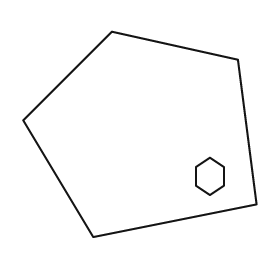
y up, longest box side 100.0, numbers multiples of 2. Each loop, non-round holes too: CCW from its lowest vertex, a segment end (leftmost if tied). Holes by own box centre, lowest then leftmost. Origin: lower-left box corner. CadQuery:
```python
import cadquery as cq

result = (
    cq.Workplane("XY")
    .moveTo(30.0, 0.0)
    .lineTo(100.0, 14.0)
    .lineTo(92.0, 76.0)
    .lineTo(38.0, 88.0)
    .lineTo(0.0, 50.0)
    .close()
    .moveTo(80.0, 18.0)
    .lineTo(86.0, 22.0)
    .lineTo(86.0, 30.0)
    .lineTo(80.0, 34.0)
    .lineTo(74.0, 30.0)
    .lineTo(74.0, 22.0)
    .close()
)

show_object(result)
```